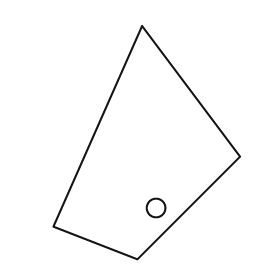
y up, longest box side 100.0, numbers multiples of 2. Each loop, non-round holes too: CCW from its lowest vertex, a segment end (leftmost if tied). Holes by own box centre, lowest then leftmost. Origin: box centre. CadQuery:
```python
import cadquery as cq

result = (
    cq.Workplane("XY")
    .moveTo(-4.0, -50.0)
    .lineTo(40.0, -6.0)
    .lineTo(-2.0, 50.0)
    .lineTo(-40.0, -36.0)
    .close()
    .moveTo(4.0, -28.0)
    .circle(4.0)
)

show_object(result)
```